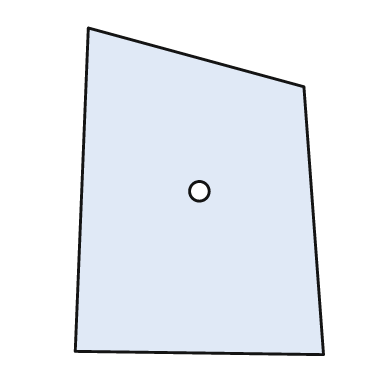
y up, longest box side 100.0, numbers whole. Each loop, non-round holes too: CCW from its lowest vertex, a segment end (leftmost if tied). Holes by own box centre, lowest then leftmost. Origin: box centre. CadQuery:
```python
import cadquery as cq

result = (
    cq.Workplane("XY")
    .moveTo(38.0, -50.0)
    .lineTo(32.0, 32.0)
    .lineTo(-34.0, 50.0)
    .lineTo(-38.0, -49.0)
    .close()
    .moveTo(0.0, 0.0)
    .circle(3.0)
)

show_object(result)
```